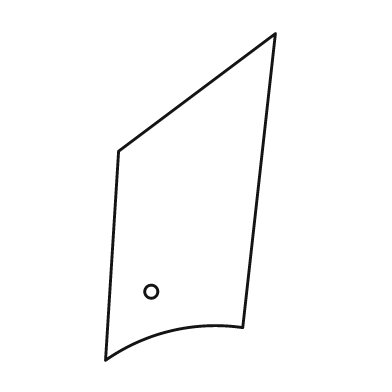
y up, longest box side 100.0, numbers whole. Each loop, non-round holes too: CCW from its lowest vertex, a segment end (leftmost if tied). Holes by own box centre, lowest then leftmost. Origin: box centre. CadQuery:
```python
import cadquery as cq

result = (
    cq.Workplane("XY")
    .moveTo(-26.0, -50.0)
    .threePointArc((-6.0, -41.0), (16.0, -40.0))
    .lineTo(26.0, 50.0)
    .lineTo(-22.0, 14.0)
    .close()
    .moveTo(-12.0, -29.0)
    .circle(2.0)
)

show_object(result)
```